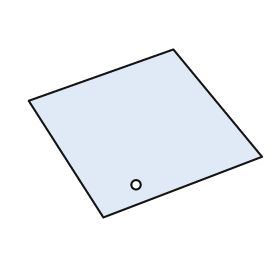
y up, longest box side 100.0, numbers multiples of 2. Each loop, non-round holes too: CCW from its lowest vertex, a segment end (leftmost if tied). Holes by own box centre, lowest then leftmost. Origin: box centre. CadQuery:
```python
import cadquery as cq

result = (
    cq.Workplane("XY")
    .moveTo(-18.0, -36.0)
    .lineTo(50.0, -10.0)
    .lineTo(12.0, 36.0)
    .lineTo(-50.0, 14.0)
    .close()
    .moveTo(-4.0, -22.0)
    .circle(2.0)
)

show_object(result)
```